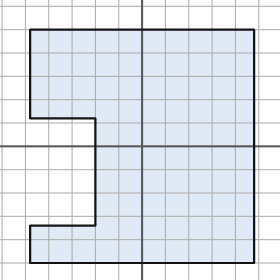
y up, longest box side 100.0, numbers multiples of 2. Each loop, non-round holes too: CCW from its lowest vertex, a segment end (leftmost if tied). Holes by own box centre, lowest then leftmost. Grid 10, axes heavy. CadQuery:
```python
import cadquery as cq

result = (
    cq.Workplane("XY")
    .moveTo(-48.0, -50.0)
    .lineTo(48.0, -50.0)
    .lineTo(48.0, 50.0)
    .lineTo(-48.0, 50.0)
    .lineTo(-48.0, 12.0)
    .lineTo(-20.0, 12.0)
    .lineTo(-20.0, -34.0)
    .lineTo(-48.0, -34.0)
    .close()
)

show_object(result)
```